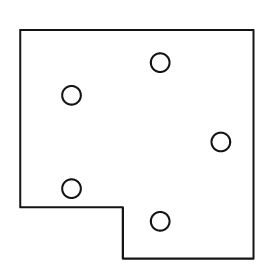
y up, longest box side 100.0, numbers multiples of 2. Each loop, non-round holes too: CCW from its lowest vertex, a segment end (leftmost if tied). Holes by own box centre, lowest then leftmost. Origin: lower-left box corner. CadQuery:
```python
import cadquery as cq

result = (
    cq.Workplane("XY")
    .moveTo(44.0, 0.0)
    .lineTo(100.0, 0.0)
    .lineTo(100.0, 98.0)
    .lineTo(0.0, 98.0)
    .lineTo(0.0, 22.0)
    .lineTo(44.0, 22.0)
    .close()
    .moveTo(60.0, 16.0)
    .circle(4.0)
    .moveTo(22.0, 30.0)
    .circle(4.0)
    .moveTo(86.0, 50.0)
    .circle(4.0)
    .moveTo(22.0, 70.0)
    .circle(4.0)
    .moveTo(60.0, 84.0)
    .circle(4.0)
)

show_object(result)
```